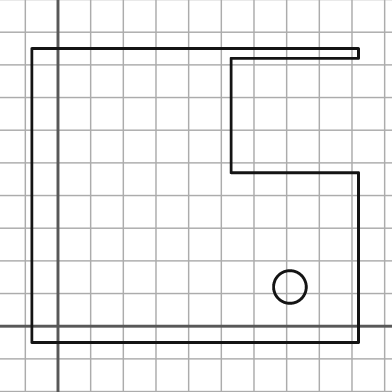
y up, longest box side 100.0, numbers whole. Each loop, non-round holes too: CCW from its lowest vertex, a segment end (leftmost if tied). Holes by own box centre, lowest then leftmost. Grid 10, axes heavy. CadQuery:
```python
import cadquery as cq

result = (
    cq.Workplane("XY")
    .moveTo(-8.0, -5.0)
    .lineTo(92.0, -5.0)
    .lineTo(92.0, 47.0)
    .lineTo(53.0, 47.0)
    .lineTo(53.0, 82.0)
    .lineTo(92.0, 82.0)
    .lineTo(92.0, 85.0)
    .lineTo(-8.0, 85.0)
    .close()
    .moveTo(71.0, 12.0)
    .circle(5.0)
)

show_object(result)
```